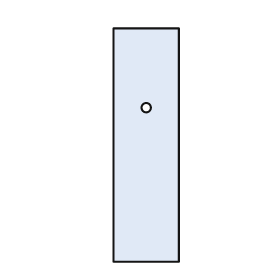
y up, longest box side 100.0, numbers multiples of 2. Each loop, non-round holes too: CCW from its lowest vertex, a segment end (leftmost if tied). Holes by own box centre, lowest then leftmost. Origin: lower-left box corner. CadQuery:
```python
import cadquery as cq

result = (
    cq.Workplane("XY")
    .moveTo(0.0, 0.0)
    .lineTo(28.0, 0.0)
    .lineTo(28.0, 100.0)
    .lineTo(0.0, 100.0)
    .close()
    .moveTo(14.0, 66.0)
    .circle(2.0)
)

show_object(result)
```